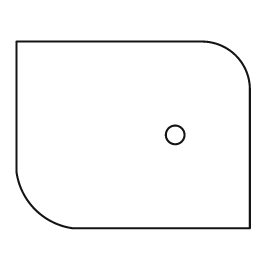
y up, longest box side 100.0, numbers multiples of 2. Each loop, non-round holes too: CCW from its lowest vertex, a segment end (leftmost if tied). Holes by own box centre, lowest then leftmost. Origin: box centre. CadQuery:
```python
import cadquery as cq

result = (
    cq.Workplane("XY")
    .moveTo(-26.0, -40.0)
    .lineTo(50.0, -40.0)
    .lineTo(50.0, 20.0)
    .threePointArc((44.0, 34.0), (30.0, 40.0))
    .lineTo(-50.0, 40.0)
    .lineTo(-50.0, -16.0)
    .threePointArc((-42.0, -32.0), (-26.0, -40.0))
    .close()
    .moveTo(18.0, 0.0)
    .circle(4.0)
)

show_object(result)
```